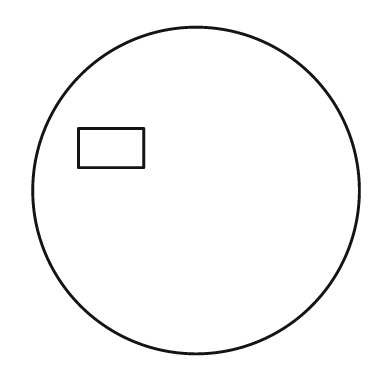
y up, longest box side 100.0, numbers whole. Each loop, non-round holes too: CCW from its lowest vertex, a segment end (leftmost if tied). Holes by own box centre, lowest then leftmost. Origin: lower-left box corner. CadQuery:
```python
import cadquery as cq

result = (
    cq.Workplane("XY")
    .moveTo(50.0, 50.0)
    .circle(50.0)
    .moveTo(14.0, 57.0)
    .lineTo(34.0, 57.0)
    .lineTo(34.0, 69.0)
    .lineTo(14.0, 69.0)
    .close()
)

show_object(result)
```